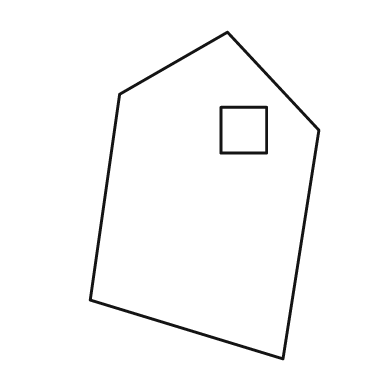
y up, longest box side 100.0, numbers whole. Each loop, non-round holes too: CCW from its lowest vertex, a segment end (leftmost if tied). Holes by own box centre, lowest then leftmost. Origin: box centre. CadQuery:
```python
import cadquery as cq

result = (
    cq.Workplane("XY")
    .moveTo(24.0, -50.0)
    .lineTo(35.0, 20.0)
    .lineTo(7.0, 50.0)
    .lineTo(-26.0, 31.0)
    .lineTo(-35.0, -32.0)
    .close()
    .moveTo(5.0, 13.0)
    .lineTo(19.0, 13.0)
    .lineTo(19.0, 27.0)
    .lineTo(5.0, 27.0)
    .close()
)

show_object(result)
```